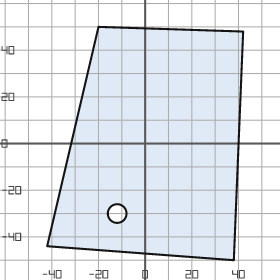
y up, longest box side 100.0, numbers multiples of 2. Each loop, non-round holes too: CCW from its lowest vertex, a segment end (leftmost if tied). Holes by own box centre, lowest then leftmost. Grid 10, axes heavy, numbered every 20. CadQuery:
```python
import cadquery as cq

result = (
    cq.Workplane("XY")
    .moveTo(38.0, -50.0)
    .lineTo(42.0, 48.0)
    .lineTo(-20.0, 50.0)
    .lineTo(-42.0, -44.0)
    .close()
    .moveTo(-12.0, -30.0)
    .circle(4.0)
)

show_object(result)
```